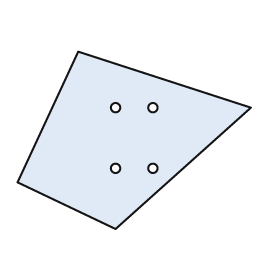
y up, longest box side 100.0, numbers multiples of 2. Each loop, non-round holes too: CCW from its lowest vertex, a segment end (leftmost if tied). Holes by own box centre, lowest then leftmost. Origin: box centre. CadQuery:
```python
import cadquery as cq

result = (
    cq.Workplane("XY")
    .moveTo(-8.0, -38.0)
    .lineTo(50.0, 14.0)
    .lineTo(-24.0, 38.0)
    .lineTo(-50.0, -18.0)
    .close()
    .moveTo(-8.0, -12.0)
    .circle(2.0)
    .moveTo(8.0, -12.0)
    .circle(2.0)
    .moveTo(-8.0, 14.0)
    .circle(2.0)
    .moveTo(8.0, 14.0)
    .circle(2.0)
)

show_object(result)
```